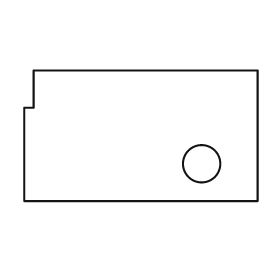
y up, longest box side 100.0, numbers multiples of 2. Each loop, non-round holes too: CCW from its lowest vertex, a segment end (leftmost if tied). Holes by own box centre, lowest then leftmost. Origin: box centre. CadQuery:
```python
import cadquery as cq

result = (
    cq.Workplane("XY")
    .moveTo(-50.0, -28.0)
    .lineTo(50.0, -28.0)
    .lineTo(50.0, 28.0)
    .lineTo(-46.0, 28.0)
    .lineTo(-46.0, 12.0)
    .lineTo(-50.0, 12.0)
    .close()
    .moveTo(26.0, -12.0)
    .circle(8.0)
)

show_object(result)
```